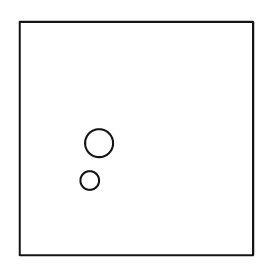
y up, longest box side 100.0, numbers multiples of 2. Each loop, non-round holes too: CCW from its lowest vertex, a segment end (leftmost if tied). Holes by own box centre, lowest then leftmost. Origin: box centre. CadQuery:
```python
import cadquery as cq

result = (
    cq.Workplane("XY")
    .moveTo(-50.0, -50.0)
    .lineTo(50.0, -50.0)
    .lineTo(50.0, 50.0)
    .lineTo(-50.0, 50.0)
    .close()
    .moveTo(-20.0, -18.0)
    .circle(4.0)
    .moveTo(-16.0, -2.0)
    .circle(6.0)
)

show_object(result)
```